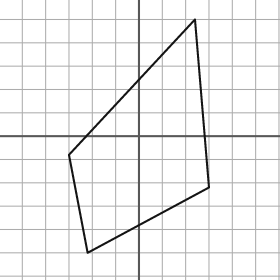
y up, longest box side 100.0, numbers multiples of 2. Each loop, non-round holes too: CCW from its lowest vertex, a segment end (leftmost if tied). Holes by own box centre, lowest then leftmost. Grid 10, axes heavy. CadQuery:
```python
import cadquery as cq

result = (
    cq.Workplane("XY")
    .moveTo(-22.0, -50.0)
    .lineTo(30.0, -22.0)
    .lineTo(24.0, 50.0)
    .lineTo(-30.0, -8.0)
    .close()
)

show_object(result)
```